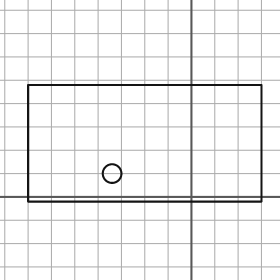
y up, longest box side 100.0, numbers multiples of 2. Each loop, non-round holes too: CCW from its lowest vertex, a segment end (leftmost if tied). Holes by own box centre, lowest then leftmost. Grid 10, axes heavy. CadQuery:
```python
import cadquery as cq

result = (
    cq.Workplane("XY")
    .moveTo(-70.0, -2.0)
    .lineTo(30.0, -2.0)
    .lineTo(30.0, 48.0)
    .lineTo(-70.0, 48.0)
    .close()
    .moveTo(-34.0, 10.0)
    .circle(4.0)
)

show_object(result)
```